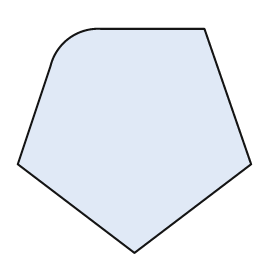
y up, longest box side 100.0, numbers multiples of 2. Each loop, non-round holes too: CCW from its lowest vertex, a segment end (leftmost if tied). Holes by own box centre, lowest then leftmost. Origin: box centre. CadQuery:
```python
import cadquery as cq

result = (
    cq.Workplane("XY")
    .moveTo(0.0, -48.0)
    .lineTo(50.0, -10.0)
    .lineTo(30.0, 48.0)
    .lineTo(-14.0, 48.0)
    .threePointArc((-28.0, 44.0), (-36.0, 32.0))
    .lineTo(-50.0, -10.0)
    .close()
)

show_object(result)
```